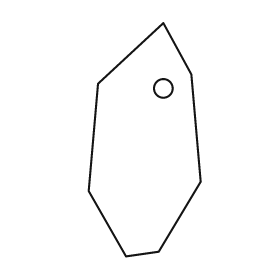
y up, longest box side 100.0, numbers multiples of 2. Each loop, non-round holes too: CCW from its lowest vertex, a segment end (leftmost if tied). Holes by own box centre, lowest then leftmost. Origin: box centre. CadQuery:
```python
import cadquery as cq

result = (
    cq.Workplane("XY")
    .moveTo(-8.0, -50.0)
    .lineTo(6.0, -48.0)
    .lineTo(24.0, -18.0)
    .lineTo(20.0, 28.0)
    .lineTo(8.0, 50.0)
    .lineTo(-20.0, 24.0)
    .lineTo(-24.0, -22.0)
    .close()
    .moveTo(8.0, 22.0)
    .circle(4.0)
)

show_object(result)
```